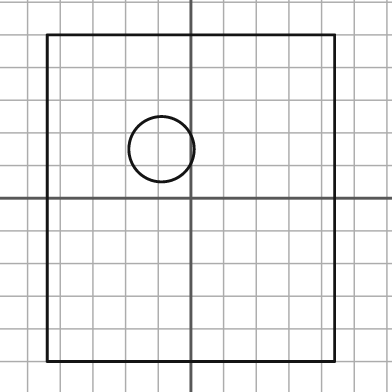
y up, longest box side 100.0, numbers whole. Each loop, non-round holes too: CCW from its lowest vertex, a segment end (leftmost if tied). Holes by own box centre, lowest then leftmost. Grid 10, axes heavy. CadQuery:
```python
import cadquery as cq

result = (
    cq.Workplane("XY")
    .moveTo(-44.0, -50.0)
    .lineTo(44.0, -50.0)
    .lineTo(44.0, 50.0)
    .lineTo(-44.0, 50.0)
    .close()
    .moveTo(-9.0, 15.0)
    .circle(10.0)
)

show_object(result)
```